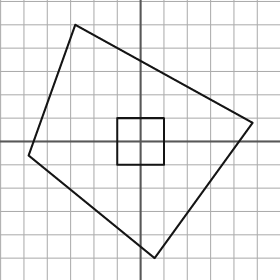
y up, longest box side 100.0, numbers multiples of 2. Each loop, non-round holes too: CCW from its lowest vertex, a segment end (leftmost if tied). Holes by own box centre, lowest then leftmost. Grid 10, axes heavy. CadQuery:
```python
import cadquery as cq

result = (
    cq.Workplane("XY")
    .moveTo(6.0, -50.0)
    .lineTo(48.0, 8.0)
    .lineTo(-28.0, 50.0)
    .lineTo(-48.0, -6.0)
    .close()
    .moveTo(-10.0, -10.0)
    .lineTo(10.0, -10.0)
    .lineTo(10.0, 10.0)
    .lineTo(-10.0, 10.0)
    .close()
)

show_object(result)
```